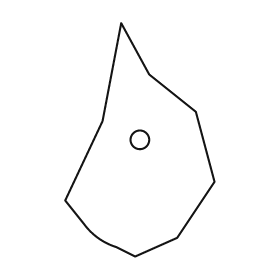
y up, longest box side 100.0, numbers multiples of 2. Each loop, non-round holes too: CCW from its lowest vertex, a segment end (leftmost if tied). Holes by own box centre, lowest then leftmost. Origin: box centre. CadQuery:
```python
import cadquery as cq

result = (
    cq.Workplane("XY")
    .moveTo(-2.0, -50.0)
    .lineTo(16.0, -42.0)
    .lineTo(32.0, -18.0)
    .lineTo(24.0, 12.0)
    .lineTo(4.0, 28.0)
    .lineTo(-8.0, 50.0)
    .lineTo(-16.0, 8.0)
    .lineTo(-32.0, -26.0)
    .lineTo(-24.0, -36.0)
    .threePointArc((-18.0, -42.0), (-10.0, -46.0))
    .close()
    .moveTo(0.0, 0.0)
    .circle(4.0)
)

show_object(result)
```